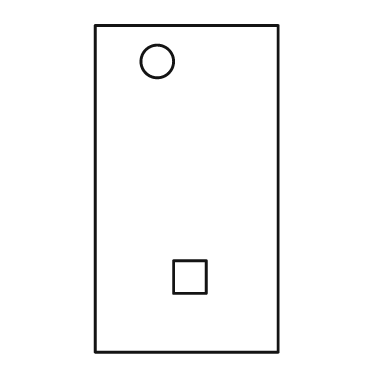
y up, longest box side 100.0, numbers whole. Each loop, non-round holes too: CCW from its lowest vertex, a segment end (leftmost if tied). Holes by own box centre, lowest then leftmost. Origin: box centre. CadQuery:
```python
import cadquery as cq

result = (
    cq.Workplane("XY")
    .moveTo(-28.0, -50.0)
    .lineTo(28.0, -50.0)
    .lineTo(28.0, 50.0)
    .lineTo(-28.0, 50.0)
    .close()
    .moveTo(-4.0, -32.0)
    .lineTo(6.0, -32.0)
    .lineTo(6.0, -22.0)
    .lineTo(-4.0, -22.0)
    .close()
    .moveTo(-9.0, 39.0)
    .circle(5.0)
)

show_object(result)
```